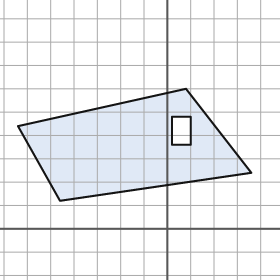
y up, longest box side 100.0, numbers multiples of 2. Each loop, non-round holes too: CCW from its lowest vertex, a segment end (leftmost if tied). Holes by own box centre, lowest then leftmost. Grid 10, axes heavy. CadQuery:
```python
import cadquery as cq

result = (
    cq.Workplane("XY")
    .moveTo(-46.0, 12.0)
    .lineTo(36.0, 24.0)
    .lineTo(8.0, 60.0)
    .lineTo(-64.0, 44.0)
    .close()
    .moveTo(2.0, 36.0)
    .lineTo(10.0, 36.0)
    .lineTo(10.0, 48.0)
    .lineTo(2.0, 48.0)
    .close()
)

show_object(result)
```